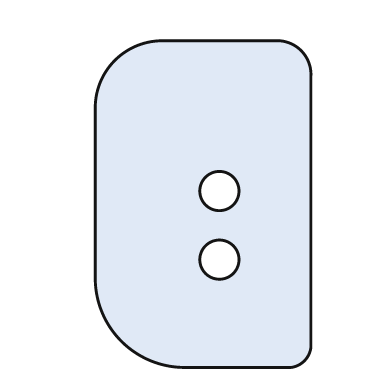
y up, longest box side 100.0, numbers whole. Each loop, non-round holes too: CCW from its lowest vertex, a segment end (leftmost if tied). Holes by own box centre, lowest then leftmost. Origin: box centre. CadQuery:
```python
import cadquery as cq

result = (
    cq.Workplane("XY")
    .moveTo(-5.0, -50.0)
    .lineTo(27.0, -50.0)
    .threePointArc((31.0, -48.0), (33.0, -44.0))
    .lineTo(33.0, 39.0)
    .threePointArc((30.0, 47.0), (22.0, 50.0))
    .lineTo(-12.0, 50.0)
    .threePointArc((-27.0, 44.0), (-33.0, 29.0))
    .lineTo(-33.0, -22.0)
    .threePointArc((-25.0, -42.0), (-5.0, -50.0))
    .close()
    .moveTo(5.0, -17.0)
    .circle(6.0)
    .moveTo(5.0, 4.0)
    .circle(6.0)
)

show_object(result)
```